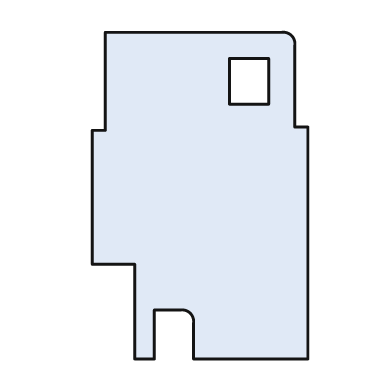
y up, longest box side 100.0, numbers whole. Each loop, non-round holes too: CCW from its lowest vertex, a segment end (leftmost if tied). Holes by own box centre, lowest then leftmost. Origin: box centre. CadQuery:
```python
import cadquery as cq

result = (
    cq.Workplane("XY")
    .moveTo(-20.0, -50.0)
    .lineTo(-14.0, -50.0)
    .lineTo(-14.0, -35.0)
    .lineTo(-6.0, -35.0)
    .threePointArc((-3.0, -36.0), (-2.0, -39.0))
    .lineTo(-2.0, -50.0)
    .lineTo(33.0, -50.0)
    .lineTo(33.0, 21.0)
    .lineTo(29.0, 21.0)
    .lineTo(29.0, 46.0)
    .threePointArc((28.0, 49.0), (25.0, 50.0))
    .lineTo(-29.0, 50.0)
    .lineTo(-29.0, 20.0)
    .lineTo(-33.0, 20.0)
    .lineTo(-33.0, -21.0)
    .lineTo(-20.0, -21.0)
    .close()
    .moveTo(9.0, 28.0)
    .lineTo(21.0, 28.0)
    .lineTo(21.0, 42.0)
    .lineTo(9.0, 42.0)
    .close()
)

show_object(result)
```